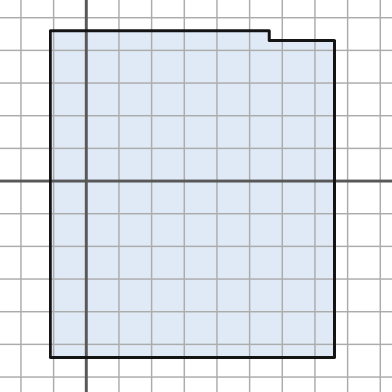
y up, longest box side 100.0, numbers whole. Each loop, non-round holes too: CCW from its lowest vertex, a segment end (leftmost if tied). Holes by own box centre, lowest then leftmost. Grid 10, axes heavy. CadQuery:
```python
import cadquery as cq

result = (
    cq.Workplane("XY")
    .moveTo(-11.0, -54.0)
    .lineTo(76.0, -54.0)
    .lineTo(76.0, 43.0)
    .lineTo(56.0, 43.0)
    .lineTo(56.0, 46.0)
    .lineTo(-11.0, 46.0)
    .close()
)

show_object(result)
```